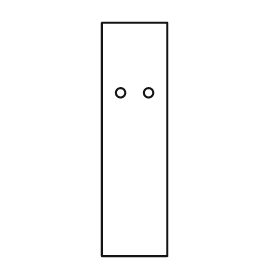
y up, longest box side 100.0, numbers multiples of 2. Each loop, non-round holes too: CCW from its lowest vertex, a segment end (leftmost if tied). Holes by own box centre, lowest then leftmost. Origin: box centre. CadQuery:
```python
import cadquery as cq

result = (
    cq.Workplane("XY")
    .moveTo(-14.0, -50.0)
    .lineTo(14.0, -50.0)
    .lineTo(14.0, 50.0)
    .lineTo(-14.0, 50.0)
    .close()
    .moveTo(-6.0, 20.0)
    .circle(2.0)
    .moveTo(6.0, 20.0)
    .circle(2.0)
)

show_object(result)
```